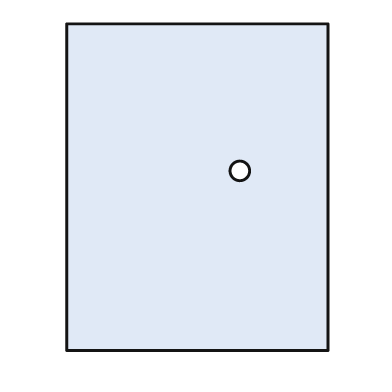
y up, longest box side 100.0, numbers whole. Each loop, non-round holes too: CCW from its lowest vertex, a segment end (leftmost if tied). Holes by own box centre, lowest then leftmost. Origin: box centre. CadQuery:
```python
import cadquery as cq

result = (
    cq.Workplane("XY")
    .moveTo(-40.0, -50.0)
    .lineTo(40.0, -50.0)
    .lineTo(40.0, 50.0)
    .lineTo(-40.0, 50.0)
    .close()
    .moveTo(13.0, 5.0)
    .circle(3.0)
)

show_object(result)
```